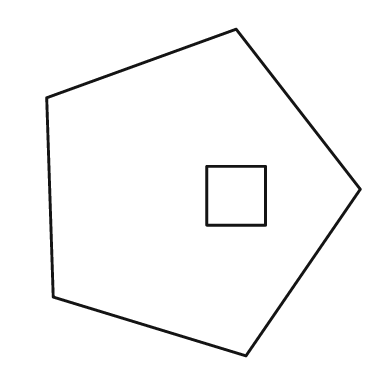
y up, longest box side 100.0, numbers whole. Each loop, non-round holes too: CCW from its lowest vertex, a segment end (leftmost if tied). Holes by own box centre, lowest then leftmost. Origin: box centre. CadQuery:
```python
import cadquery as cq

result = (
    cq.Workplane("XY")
    .moveTo(13.0, -50.0)
    .lineTo(48.0, 1.0)
    .lineTo(10.0, 50.0)
    .lineTo(-48.0, 29.0)
    .lineTo(-46.0, -32.0)
    .close()
    .moveTo(1.0, -10.0)
    .lineTo(19.0, -10.0)
    .lineTo(19.0, 8.0)
    .lineTo(1.0, 8.0)
    .close()
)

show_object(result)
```